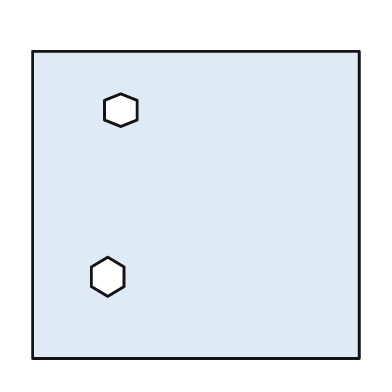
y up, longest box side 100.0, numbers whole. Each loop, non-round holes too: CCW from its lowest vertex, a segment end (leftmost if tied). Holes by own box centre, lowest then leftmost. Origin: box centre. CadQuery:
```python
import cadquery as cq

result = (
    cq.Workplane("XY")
    .moveTo(-50.0, -47.0)
    .lineTo(50.0, -47.0)
    .lineTo(50.0, 47.0)
    .lineTo(-50.0, 47.0)
    .close()
    .moveTo(-27.0, -28.0)
    .lineTo(-22.0, -25.0)
    .lineTo(-22.0, -19.0)
    .lineTo(-27.0, -16.0)
    .lineTo(-32.0, -19.0)
    .lineTo(-32.0, -25.0)
    .close()
    .moveTo(-23.0, 24.0)
    .lineTo(-18.0, 26.0)
    .lineTo(-18.0, 32.0)
    .lineTo(-23.0, 34.0)
    .lineTo(-28.0, 32.0)
    .lineTo(-28.0, 26.0)
    .close()
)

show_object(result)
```